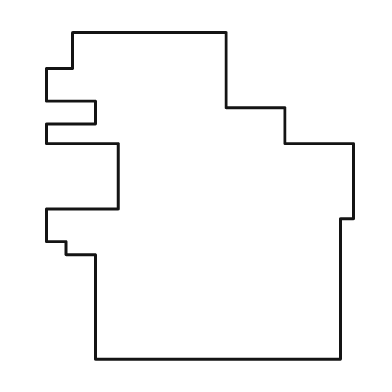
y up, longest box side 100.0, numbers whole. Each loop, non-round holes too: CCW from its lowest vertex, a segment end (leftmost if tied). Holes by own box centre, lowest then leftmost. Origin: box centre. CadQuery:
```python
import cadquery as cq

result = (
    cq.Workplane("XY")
    .moveTo(-32.0, -50.0)
    .lineTo(43.0, -50.0)
    .lineTo(43.0, -7.0)
    .lineTo(47.0, -7.0)
    .lineTo(47.0, 16.0)
    .lineTo(26.0, 16.0)
    .lineTo(26.0, 27.0)
    .lineTo(8.0, 27.0)
    .lineTo(8.0, 50.0)
    .lineTo(-39.0, 50.0)
    .lineTo(-39.0, 39.0)
    .lineTo(-47.0, 39.0)
    .lineTo(-47.0, 29.0)
    .lineTo(-32.0, 29.0)
    .lineTo(-32.0, 22.0)
    .lineTo(-47.0, 22.0)
    .lineTo(-47.0, 16.0)
    .lineTo(-25.0, 16.0)
    .lineTo(-25.0, -4.0)
    .lineTo(-47.0, -4.0)
    .lineTo(-47.0, -14.0)
    .lineTo(-41.0, -14.0)
    .lineTo(-41.0, -18.0)
    .lineTo(-32.0, -18.0)
    .close()
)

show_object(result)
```